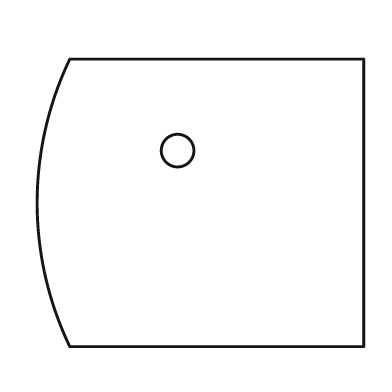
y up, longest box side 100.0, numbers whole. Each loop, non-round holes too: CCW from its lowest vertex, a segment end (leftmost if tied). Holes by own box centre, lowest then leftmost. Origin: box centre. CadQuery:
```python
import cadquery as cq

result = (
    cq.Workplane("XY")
    .moveTo(-40.0, -44.0)
    .lineTo(50.0, -44.0)
    .lineTo(50.0, 44.0)
    .lineTo(-40.0, 44.0)
    .threePointArc((-50.0, 0.0), (-40.0, -44.0))
    .close()
    .moveTo(-7.0, 16.0)
    .circle(5.0)
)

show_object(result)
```